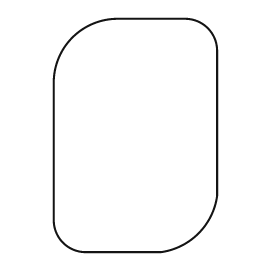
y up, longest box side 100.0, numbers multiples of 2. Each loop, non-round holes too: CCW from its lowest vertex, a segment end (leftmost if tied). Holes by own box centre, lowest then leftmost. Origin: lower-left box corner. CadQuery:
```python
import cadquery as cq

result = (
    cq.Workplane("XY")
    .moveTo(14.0, 0.0)
    .lineTo(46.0, 0.0)
    .threePointArc((62.0, 8.0), (70.0, 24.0))
    .lineTo(70.0, 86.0)
    .threePointArc((66.0, 96.0), (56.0, 100.0))
    .lineTo(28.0, 100.0)
    .threePointArc((8.0, 92.0), (0.0, 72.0))
    .lineTo(0.0, 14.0)
    .threePointArc((4.0, 4.0), (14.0, 0.0))
    .close()
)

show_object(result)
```